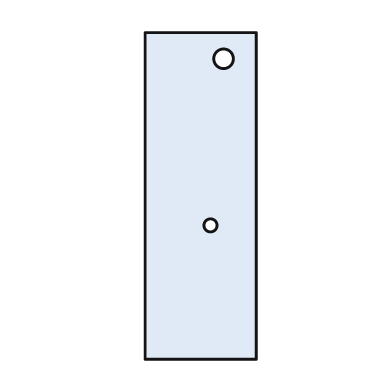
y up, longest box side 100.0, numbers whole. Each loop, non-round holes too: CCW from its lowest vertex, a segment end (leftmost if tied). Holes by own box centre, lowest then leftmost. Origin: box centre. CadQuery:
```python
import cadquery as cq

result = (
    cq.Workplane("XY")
    .moveTo(-17.0, -50.0)
    .lineTo(17.0, -50.0)
    .lineTo(17.0, 50.0)
    .lineTo(-17.0, 50.0)
    .close()
    .moveTo(3.0, -9.0)
    .circle(2.0)
    .moveTo(7.0, 42.0)
    .circle(3.0)
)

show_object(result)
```